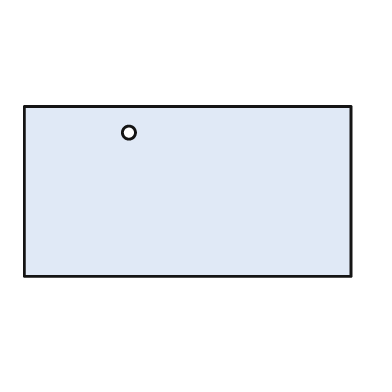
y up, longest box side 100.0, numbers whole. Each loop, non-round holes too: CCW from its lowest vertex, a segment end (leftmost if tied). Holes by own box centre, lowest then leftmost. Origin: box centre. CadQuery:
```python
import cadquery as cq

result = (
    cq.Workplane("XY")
    .moveTo(-50.0, -26.0)
    .lineTo(50.0, -26.0)
    .lineTo(50.0, 26.0)
    .lineTo(-50.0, 26.0)
    .close()
    .moveTo(-18.0, 18.0)
    .circle(2.0)
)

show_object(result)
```